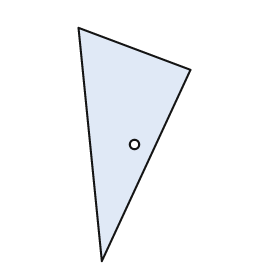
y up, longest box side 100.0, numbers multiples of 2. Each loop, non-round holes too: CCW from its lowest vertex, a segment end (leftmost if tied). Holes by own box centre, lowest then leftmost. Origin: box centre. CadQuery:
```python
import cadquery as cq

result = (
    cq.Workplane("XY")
    .moveTo(-14.0, -50.0)
    .lineTo(24.0, 32.0)
    .lineTo(-24.0, 50.0)
    .close()
    .moveTo(0.0, 0.0)
    .circle(2.0)
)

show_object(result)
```